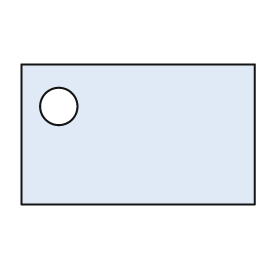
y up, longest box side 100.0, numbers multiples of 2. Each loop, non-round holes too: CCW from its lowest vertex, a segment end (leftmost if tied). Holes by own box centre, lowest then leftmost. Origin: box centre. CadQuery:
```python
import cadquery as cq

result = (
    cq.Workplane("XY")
    .moveTo(-50.0, -30.0)
    .lineTo(50.0, -30.0)
    .lineTo(50.0, 30.0)
    .lineTo(-50.0, 30.0)
    .close()
    .moveTo(-34.0, 12.0)
    .circle(8.0)
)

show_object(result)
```